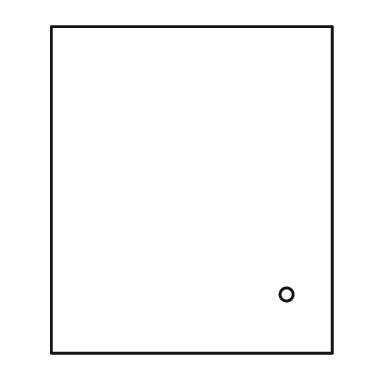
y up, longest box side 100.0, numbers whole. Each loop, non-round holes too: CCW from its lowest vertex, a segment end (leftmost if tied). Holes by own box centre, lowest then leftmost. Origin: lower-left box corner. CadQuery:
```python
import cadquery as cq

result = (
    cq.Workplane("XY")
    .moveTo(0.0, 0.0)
    .lineTo(86.0, 0.0)
    .lineTo(86.0, 100.0)
    .lineTo(0.0, 100.0)
    .close()
    .moveTo(72.0, 18.0)
    .circle(2.0)
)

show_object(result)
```